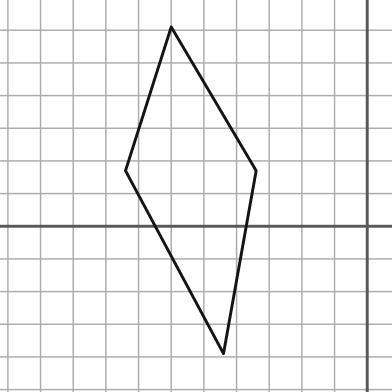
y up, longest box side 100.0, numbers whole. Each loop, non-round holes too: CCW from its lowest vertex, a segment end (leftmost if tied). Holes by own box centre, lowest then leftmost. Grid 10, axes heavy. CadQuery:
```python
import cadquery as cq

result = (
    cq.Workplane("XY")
    .moveTo(-44.0, -39.0)
    .lineTo(-34.0, 17.0)
    .lineTo(-60.0, 61.0)
    .lineTo(-74.0, 17.0)
    .close()
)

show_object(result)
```